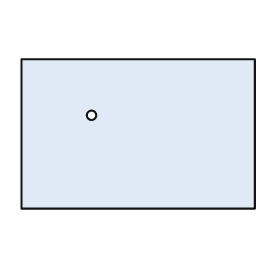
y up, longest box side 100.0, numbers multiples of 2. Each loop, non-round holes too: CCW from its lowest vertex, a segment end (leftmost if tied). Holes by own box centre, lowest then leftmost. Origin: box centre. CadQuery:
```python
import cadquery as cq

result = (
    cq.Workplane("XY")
    .moveTo(-50.0, -32.0)
    .lineTo(50.0, -32.0)
    .lineTo(50.0, 32.0)
    .lineTo(-50.0, 32.0)
    .close()
    .moveTo(-20.0, 8.0)
    .circle(2.0)
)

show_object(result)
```